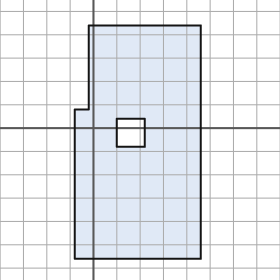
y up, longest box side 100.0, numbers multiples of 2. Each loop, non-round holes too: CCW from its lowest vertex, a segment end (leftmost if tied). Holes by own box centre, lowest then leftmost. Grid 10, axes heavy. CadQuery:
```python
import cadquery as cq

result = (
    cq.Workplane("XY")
    .moveTo(-8.0, -56.0)
    .lineTo(46.0, -56.0)
    .lineTo(46.0, 44.0)
    .lineTo(-2.0, 44.0)
    .lineTo(-2.0, 8.0)
    .lineTo(-8.0, 8.0)
    .close()
    .moveTo(10.0, -8.0)
    .lineTo(22.0, -8.0)
    .lineTo(22.0, 4.0)
    .lineTo(10.0, 4.0)
    .close()
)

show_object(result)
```